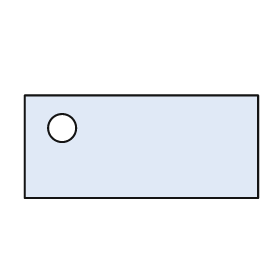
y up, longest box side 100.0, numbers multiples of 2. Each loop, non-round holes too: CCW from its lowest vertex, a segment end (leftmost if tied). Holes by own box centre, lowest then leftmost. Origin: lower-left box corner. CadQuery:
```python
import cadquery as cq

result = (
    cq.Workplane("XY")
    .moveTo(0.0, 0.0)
    .lineTo(100.0, 0.0)
    .lineTo(100.0, 44.0)
    .lineTo(0.0, 44.0)
    .close()
    .moveTo(16.0, 30.0)
    .circle(6.0)
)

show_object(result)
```